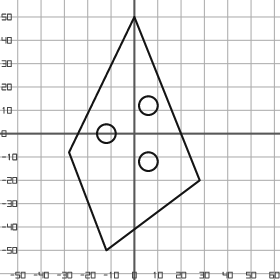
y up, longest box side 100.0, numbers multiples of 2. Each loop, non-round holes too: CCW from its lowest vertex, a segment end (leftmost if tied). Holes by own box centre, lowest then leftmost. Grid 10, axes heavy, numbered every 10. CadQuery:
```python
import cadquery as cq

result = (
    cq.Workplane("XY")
    .moveTo(-12.0, -50.0)
    .lineTo(28.0, -20.0)
    .lineTo(0.0, 50.0)
    .lineTo(-28.0, -8.0)
    .close()
    .moveTo(6.0, -12.0)
    .circle(4.0)
    .moveTo(-12.0, 0.0)
    .circle(4.0)
    .moveTo(6.0, 12.0)
    .circle(4.0)
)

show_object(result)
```